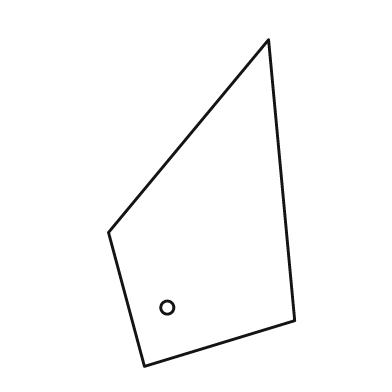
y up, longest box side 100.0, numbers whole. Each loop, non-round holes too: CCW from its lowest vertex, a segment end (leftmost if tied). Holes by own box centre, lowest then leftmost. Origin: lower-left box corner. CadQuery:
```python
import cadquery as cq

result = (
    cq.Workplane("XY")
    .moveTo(11.0, 0.0)
    .lineTo(57.0, 14.0)
    .lineTo(49.0, 100.0)
    .lineTo(0.0, 41.0)
    .close()
    .moveTo(18.0, 18.0)
    .circle(2.0)
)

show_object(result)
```